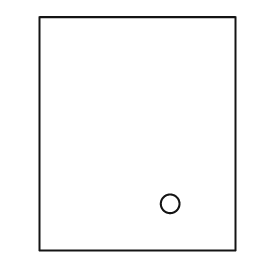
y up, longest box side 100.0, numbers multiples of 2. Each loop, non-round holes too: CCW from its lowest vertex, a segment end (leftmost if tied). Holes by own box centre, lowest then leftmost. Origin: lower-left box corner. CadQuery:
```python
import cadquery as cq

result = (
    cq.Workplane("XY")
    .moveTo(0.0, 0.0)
    .lineTo(84.0, 0.0)
    .lineTo(84.0, 100.0)
    .lineTo(0.0, 100.0)
    .close()
    .moveTo(56.0, 20.0)
    .circle(4.0)
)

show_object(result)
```